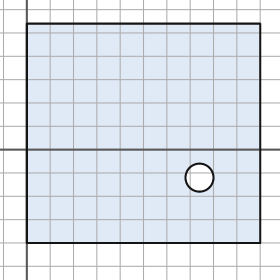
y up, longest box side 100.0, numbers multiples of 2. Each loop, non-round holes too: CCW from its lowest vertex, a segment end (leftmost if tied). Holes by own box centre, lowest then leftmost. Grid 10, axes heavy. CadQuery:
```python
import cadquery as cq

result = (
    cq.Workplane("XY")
    .moveTo(0.0, -40.0)
    .lineTo(100.0, -40.0)
    .lineTo(100.0, 54.0)
    .lineTo(0.0, 54.0)
    .close()
    .moveTo(74.0, -12.0)
    .circle(6.0)
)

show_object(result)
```